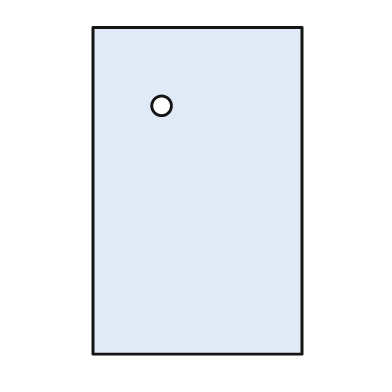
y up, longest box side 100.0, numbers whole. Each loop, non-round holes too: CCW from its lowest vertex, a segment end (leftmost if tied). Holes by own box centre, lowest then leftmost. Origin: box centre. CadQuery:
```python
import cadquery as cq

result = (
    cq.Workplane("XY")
    .moveTo(-32.0, -50.0)
    .lineTo(32.0, -50.0)
    .lineTo(32.0, 50.0)
    .lineTo(-32.0, 50.0)
    .close()
    .moveTo(-11.0, 26.0)
    .circle(3.0)
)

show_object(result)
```